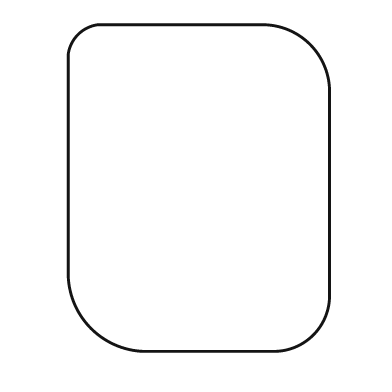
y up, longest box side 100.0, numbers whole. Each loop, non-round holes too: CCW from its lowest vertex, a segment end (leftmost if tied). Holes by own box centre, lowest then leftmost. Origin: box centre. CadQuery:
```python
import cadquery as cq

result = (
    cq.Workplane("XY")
    .moveTo(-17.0, -50.0)
    .lineTo(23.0, -50.0)
    .threePointArc((35.0, -45.0), (40.0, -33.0))
    .lineTo(40.0, 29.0)
    .threePointArc((34.0, 44.0), (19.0, 50.0))
    .lineTo(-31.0, 50.0)
    .threePointArc((-37.0, 47.0), (-40.0, 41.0))
    .lineTo(-40.0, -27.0)
    .threePointArc((-33.0, -43.0), (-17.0, -50.0))
    .close()
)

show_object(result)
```